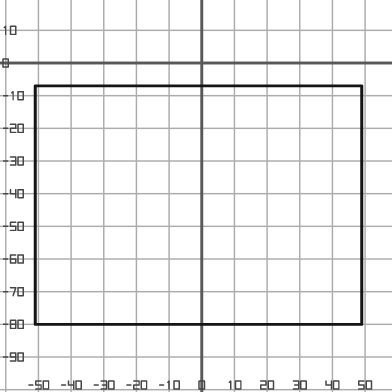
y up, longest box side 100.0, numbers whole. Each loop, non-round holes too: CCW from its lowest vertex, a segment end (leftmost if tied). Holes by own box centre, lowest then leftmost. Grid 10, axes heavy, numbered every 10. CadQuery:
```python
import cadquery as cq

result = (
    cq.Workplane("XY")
    .moveTo(-51.0, -80.0)
    .lineTo(49.0, -80.0)
    .lineTo(49.0, -7.0)
    .lineTo(-51.0, -7.0)
    .close()
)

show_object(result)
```